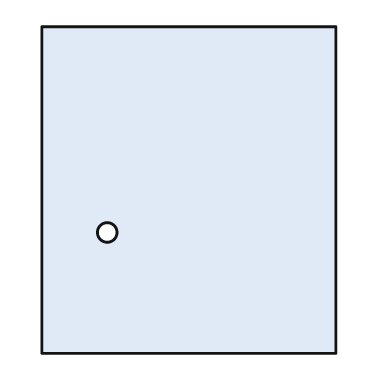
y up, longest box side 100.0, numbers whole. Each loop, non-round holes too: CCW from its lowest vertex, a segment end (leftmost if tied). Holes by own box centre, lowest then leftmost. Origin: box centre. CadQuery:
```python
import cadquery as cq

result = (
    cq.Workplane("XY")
    .moveTo(-45.0, -50.0)
    .lineTo(45.0, -50.0)
    .lineTo(45.0, 50.0)
    .lineTo(-45.0, 50.0)
    .close()
    .moveTo(-25.0, -13.0)
    .circle(3.0)
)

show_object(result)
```